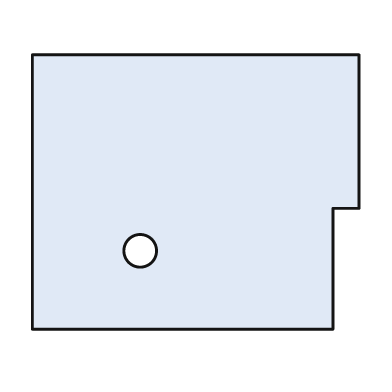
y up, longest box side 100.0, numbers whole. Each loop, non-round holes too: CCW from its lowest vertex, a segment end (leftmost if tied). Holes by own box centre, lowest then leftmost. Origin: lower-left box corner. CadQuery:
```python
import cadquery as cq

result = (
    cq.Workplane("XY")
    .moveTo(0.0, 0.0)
    .lineTo(92.0, 0.0)
    .lineTo(92.0, 37.0)
    .lineTo(100.0, 37.0)
    .lineTo(100.0, 84.0)
    .lineTo(0.0, 84.0)
    .close()
    .moveTo(33.0, 24.0)
    .circle(5.0)
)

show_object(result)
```